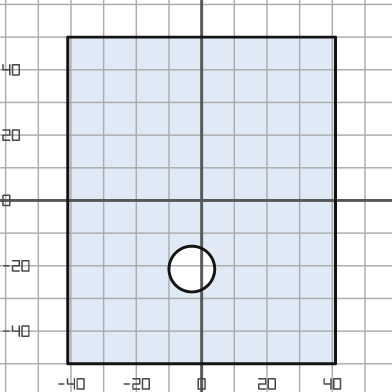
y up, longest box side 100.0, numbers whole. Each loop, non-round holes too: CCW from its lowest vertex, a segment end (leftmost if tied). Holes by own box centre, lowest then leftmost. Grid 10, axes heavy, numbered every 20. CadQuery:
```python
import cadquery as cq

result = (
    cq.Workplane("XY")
    .moveTo(-41.0, -50.0)
    .lineTo(41.0, -50.0)
    .lineTo(41.0, 50.0)
    .lineTo(-41.0, 50.0)
    .close()
    .moveTo(-3.0, -21.0)
    .circle(7.0)
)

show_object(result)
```